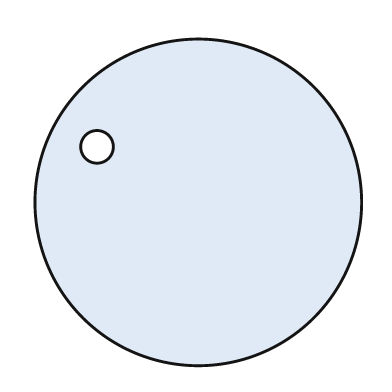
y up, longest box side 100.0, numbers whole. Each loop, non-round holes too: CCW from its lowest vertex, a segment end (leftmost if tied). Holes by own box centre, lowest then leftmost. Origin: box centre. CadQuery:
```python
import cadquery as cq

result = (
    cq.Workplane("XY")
    .moveTo(0.0, 0.0)
    .circle(50.0)
    .moveTo(-31.0, 17.0)
    .circle(5.0)
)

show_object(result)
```